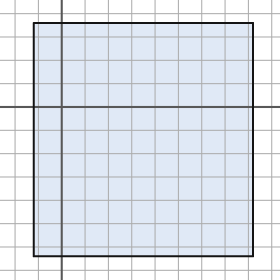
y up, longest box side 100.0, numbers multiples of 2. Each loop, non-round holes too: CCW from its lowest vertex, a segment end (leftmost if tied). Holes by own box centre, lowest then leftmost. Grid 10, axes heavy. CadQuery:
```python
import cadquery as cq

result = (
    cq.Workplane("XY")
    .moveTo(-12.0, -64.0)
    .lineTo(82.0, -64.0)
    .lineTo(82.0, 36.0)
    .lineTo(-12.0, 36.0)
    .close()
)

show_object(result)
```